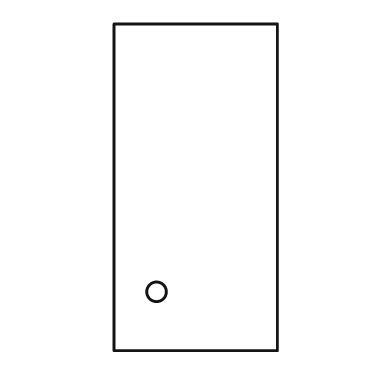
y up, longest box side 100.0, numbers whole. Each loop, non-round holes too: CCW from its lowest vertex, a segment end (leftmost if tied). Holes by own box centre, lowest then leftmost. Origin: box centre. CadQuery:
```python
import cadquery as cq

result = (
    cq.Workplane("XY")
    .moveTo(-25.0, -50.0)
    .lineTo(25.0, -50.0)
    .lineTo(25.0, 50.0)
    .lineTo(-25.0, 50.0)
    .close()
    .moveTo(-12.0, -32.0)
    .circle(3.0)
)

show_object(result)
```